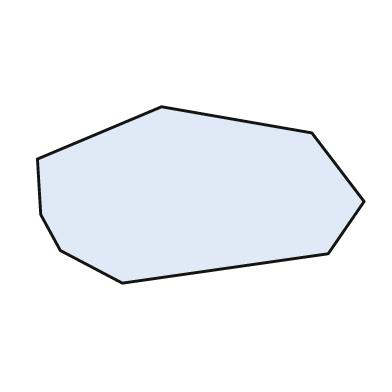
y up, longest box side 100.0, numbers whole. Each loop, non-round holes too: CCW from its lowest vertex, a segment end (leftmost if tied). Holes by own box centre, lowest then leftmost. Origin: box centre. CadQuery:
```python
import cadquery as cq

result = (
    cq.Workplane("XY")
    .moveTo(-24.0, -27.0)
    .lineTo(39.0, -18.0)
    .lineTo(50.0, -2.0)
    .lineTo(34.0, 19.0)
    .lineTo(-12.0, 27.0)
    .lineTo(-50.0, 11.0)
    .lineTo(-49.0, -6.0)
    .lineTo(-43.0, -17.0)
    .close()
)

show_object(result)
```